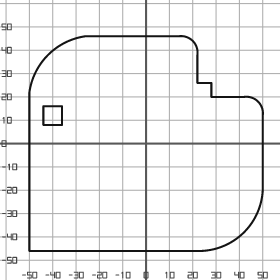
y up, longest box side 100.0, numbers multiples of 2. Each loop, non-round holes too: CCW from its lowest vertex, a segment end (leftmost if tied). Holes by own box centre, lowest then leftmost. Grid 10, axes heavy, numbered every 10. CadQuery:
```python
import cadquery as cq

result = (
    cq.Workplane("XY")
    .moveTo(-50.0, -46.0)
    .lineTo(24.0, -46.0)
    .threePointArc((42.0, -38.0), (50.0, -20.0))
    .lineTo(50.0, 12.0)
    .threePointArc((48.0, 18.0), (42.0, 20.0))
    .lineTo(28.0, 20.0)
    .lineTo(28.0, 26.0)
    .lineTo(22.0, 26.0)
    .lineTo(22.0, 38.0)
    .threePointArc((20.0, 44.0), (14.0, 46.0))
    .lineTo(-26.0, 46.0)
    .threePointArc((-42.0, 38.0), (-50.0, 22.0))
    .close()
    .moveTo(-44.0, 8.0)
    .lineTo(-36.0, 8.0)
    .lineTo(-36.0, 16.0)
    .lineTo(-44.0, 16.0)
    .close()
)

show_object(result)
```